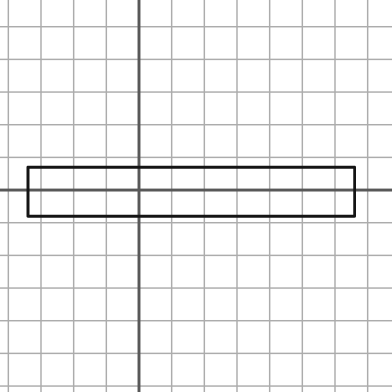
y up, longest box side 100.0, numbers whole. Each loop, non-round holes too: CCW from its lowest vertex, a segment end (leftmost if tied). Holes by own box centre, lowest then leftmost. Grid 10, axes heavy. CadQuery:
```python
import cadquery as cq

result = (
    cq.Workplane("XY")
    .moveTo(-34.0, -8.0)
    .lineTo(66.0, -8.0)
    .lineTo(66.0, 7.0)
    .lineTo(-34.0, 7.0)
    .close()
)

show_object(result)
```